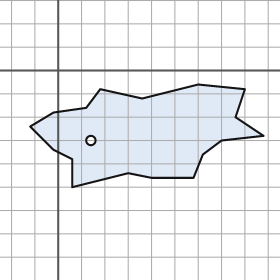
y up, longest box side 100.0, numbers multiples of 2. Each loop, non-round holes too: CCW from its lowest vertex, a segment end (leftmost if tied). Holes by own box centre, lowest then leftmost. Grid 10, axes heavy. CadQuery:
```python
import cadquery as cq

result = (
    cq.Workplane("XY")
    .moveTo(6.0, -50.0)
    .lineTo(30.0, -44.0)
    .lineTo(40.0, -46.0)
    .lineTo(58.0, -46.0)
    .lineTo(62.0, -36.0)
    .lineTo(70.0, -30.0)
    .lineTo(88.0, -28.0)
    .lineTo(76.0, -20.0)
    .lineTo(80.0, -8.0)
    .lineTo(60.0, -6.0)
    .lineTo(36.0, -12.0)
    .lineTo(18.0, -8.0)
    .lineTo(12.0, -16.0)
    .lineTo(-2.0, -18.0)
    .lineTo(-12.0, -24.0)
    .lineTo(-2.0, -34.0)
    .lineTo(6.0, -38.0)
    .close()
    .moveTo(14.0, -30.0)
    .circle(2.0)
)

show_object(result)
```